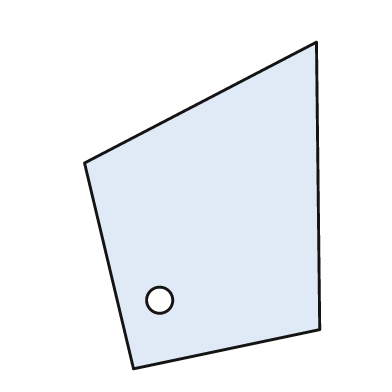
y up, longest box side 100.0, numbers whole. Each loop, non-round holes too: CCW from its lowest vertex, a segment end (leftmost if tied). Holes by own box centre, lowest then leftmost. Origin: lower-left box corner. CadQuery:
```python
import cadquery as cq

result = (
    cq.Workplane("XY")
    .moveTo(15.0, 0.0)
    .lineTo(72.0, 12.0)
    .lineTo(71.0, 100.0)
    .lineTo(0.0, 63.0)
    .close()
    .moveTo(23.0, 21.0)
    .circle(4.0)
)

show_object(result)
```